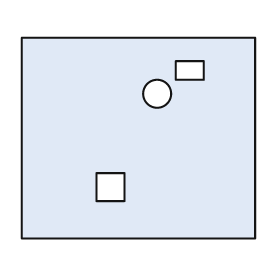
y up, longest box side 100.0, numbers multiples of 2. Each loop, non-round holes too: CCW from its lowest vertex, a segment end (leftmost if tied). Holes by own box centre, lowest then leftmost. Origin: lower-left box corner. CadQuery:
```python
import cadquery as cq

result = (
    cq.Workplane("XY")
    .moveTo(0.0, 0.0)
    .lineTo(100.0, 0.0)
    .lineTo(100.0, 86.0)
    .lineTo(0.0, 86.0)
    .close()
    .moveTo(32.0, 16.0)
    .lineTo(44.0, 16.0)
    .lineTo(44.0, 28.0)
    .lineTo(32.0, 28.0)
    .close()
    .moveTo(58.0, 62.0)
    .circle(6.0)
    .moveTo(66.0, 68.0)
    .lineTo(78.0, 68.0)
    .lineTo(78.0, 76.0)
    .lineTo(66.0, 76.0)
    .close()
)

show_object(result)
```